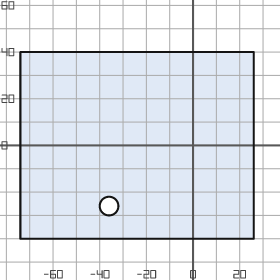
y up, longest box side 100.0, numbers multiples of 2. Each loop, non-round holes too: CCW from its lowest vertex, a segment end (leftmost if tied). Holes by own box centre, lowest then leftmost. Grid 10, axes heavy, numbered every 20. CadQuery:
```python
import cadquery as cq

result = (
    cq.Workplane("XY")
    .moveTo(-74.0, -40.0)
    .lineTo(26.0, -40.0)
    .lineTo(26.0, 40.0)
    .lineTo(-74.0, 40.0)
    .close()
    .moveTo(-36.0, -26.0)
    .circle(4.0)
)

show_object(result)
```